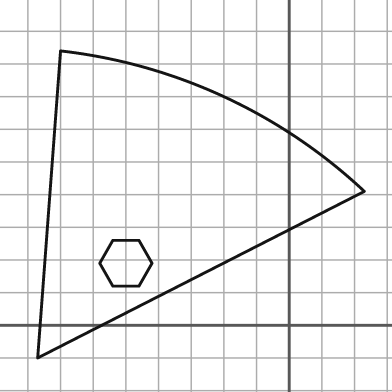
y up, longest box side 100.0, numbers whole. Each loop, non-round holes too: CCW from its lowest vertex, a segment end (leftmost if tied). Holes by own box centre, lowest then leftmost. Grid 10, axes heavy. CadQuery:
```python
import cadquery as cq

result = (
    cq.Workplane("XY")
    .moveTo(-77.0, -10.0)
    .lineTo(23.0, 41.0)
    .threePointArc((-20.0, 70.0), (-70.0, 84.0))
    .close()
    .moveTo(-54.0, 12.0)
    .lineTo(-46.0, 12.0)
    .lineTo(-42.0, 19.0)
    .lineTo(-46.0, 26.0)
    .lineTo(-54.0, 26.0)
    .lineTo(-58.0, 19.0)
    .close()
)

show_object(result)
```